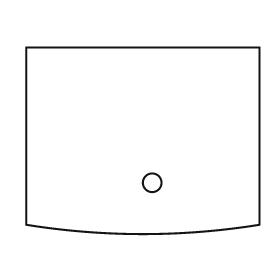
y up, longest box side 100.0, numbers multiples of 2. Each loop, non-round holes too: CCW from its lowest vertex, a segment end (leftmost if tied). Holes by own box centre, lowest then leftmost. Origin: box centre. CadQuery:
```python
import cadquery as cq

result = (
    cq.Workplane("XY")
    .moveTo(-50.0, -36.0)
    .threePointArc((0.0, -40.0), (50.0, -36.0))
    .lineTo(50.0, 40.0)
    .lineTo(-50.0, 40.0)
    .close()
    .moveTo(4.0, -18.0)
    .circle(4.0)
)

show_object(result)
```